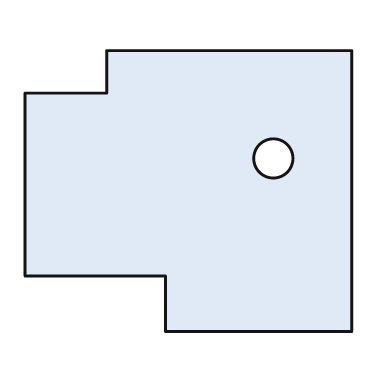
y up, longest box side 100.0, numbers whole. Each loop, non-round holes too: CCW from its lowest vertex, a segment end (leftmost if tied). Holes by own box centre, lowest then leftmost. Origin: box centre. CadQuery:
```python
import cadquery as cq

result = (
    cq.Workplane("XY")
    .moveTo(-7.0, -43.0)
    .lineTo(50.0, -43.0)
    .lineTo(50.0, 43.0)
    .lineTo(-25.0, 43.0)
    .lineTo(-25.0, 30.0)
    .lineTo(-50.0, 30.0)
    .lineTo(-50.0, -26.0)
    .lineTo(-7.0, -26.0)
    .close()
    .moveTo(26.0, 10.0)
    .circle(6.0)
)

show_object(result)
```